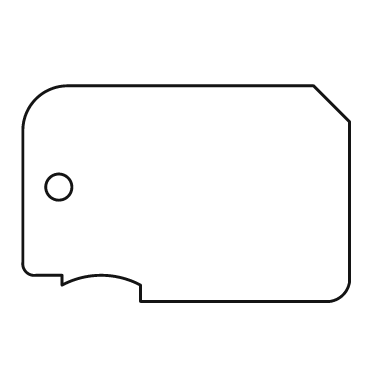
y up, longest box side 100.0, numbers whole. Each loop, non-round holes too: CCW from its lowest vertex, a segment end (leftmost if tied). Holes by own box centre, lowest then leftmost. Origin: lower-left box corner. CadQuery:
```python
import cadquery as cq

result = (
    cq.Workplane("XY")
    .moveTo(36.0, 0.0)
    .lineTo(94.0, 0.0)
    .threePointArc((98.0, 2.0), (100.0, 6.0))
    .lineTo(100.0, 55.0)
    .lineTo(89.0, 66.0)
    .lineTo(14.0, 66.0)
    .threePointArc((4.0, 62.0), (0.0, 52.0))
    .lineTo(0.0, 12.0)
    .threePointArc((1.0, 9.0), (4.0, 8.0))
    .lineTo(12.0, 8.0)
    .lineTo(12.0, 5.0)
    .threePointArc((24.0, 8.0), (36.0, 5.0))
    .close()
    .moveTo(11.0, 35.0)
    .circle(4.0)
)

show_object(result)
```